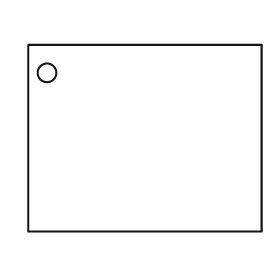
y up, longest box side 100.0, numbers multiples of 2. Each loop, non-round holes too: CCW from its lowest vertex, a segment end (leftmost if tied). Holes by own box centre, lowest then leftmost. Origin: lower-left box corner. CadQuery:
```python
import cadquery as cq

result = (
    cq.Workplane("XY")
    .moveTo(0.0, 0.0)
    .lineTo(100.0, 0.0)
    .lineTo(100.0, 80.0)
    .lineTo(0.0, 80.0)
    .close()
    .moveTo(8.0, 68.0)
    .circle(4.0)
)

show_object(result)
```